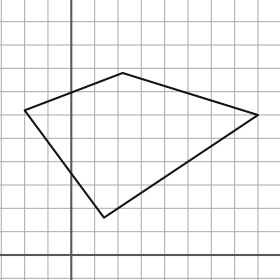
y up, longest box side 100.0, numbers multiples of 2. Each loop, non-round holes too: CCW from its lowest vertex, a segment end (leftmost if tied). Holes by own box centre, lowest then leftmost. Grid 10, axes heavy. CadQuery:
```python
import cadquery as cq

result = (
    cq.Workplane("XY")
    .moveTo(14.0, 16.0)
    .lineTo(80.0, 60.0)
    .lineTo(22.0, 78.0)
    .lineTo(-20.0, 62.0)
    .close()
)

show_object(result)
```